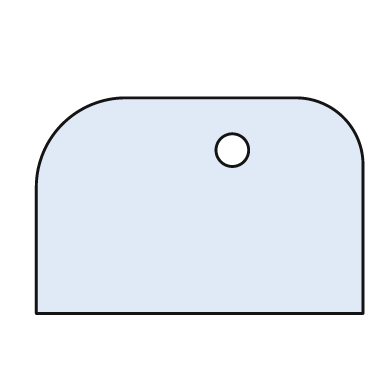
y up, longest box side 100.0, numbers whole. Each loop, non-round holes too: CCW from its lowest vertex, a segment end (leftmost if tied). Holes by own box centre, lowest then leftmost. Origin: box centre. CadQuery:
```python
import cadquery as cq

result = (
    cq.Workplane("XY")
    .moveTo(-50.0, -33.0)
    .lineTo(50.0, -33.0)
    .lineTo(50.0, 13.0)
    .threePointArc((44.0, 27.0), (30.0, 33.0))
    .lineTo(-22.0, 33.0)
    .threePointArc((-42.0, 25.0), (-50.0, 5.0))
    .close()
    .moveTo(10.0, 17.0)
    .circle(5.0)
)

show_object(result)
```